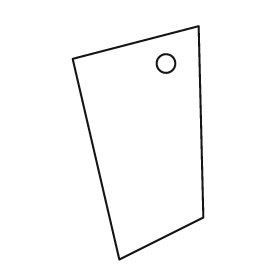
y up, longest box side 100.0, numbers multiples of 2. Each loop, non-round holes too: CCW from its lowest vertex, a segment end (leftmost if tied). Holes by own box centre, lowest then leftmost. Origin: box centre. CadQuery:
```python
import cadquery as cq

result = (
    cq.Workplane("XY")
    .moveTo(-8.0, -50.0)
    .lineTo(28.0, -32.0)
    .lineTo(26.0, 50.0)
    .lineTo(-28.0, 36.0)
    .close()
    .moveTo(12.0, 34.0)
    .circle(4.0)
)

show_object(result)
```